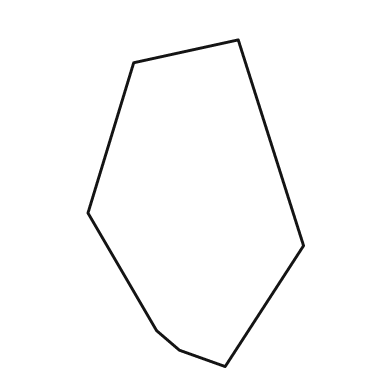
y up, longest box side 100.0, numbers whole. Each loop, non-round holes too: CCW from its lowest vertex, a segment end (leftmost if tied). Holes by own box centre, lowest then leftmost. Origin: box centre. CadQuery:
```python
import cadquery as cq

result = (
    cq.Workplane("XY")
    .moveTo(9.0, -50.0)
    .lineTo(33.0, -13.0)
    .lineTo(13.0, 50.0)
    .lineTo(-19.0, 43.0)
    .lineTo(-33.0, -3.0)
    .lineTo(-12.0, -39.0)
    .lineTo(-5.0, -45.0)
    .close()
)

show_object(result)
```